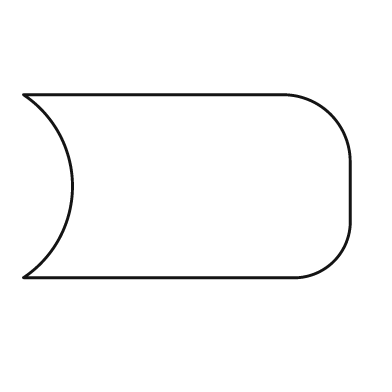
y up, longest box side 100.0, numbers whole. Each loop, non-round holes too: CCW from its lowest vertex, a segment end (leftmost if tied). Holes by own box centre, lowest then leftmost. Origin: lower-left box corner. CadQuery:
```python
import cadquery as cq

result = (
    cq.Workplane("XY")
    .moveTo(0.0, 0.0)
    .lineTo(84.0, 0.0)
    .threePointArc((95.0, 5.0), (100.0, 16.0))
    .lineTo(100.0, 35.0)
    .threePointArc((94.0, 50.0), (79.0, 56.0))
    .lineTo(0.0, 56.0)
    .threePointArc((15.0, 28.0), (0.0, 0.0))
    .close()
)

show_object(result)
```